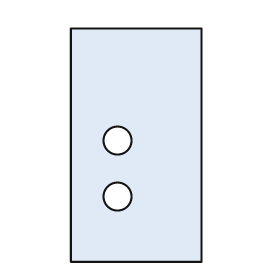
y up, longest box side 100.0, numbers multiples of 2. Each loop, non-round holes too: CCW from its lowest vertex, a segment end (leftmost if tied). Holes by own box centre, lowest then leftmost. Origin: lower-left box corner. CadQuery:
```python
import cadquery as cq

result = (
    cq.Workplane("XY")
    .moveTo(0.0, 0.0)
    .lineTo(56.0, 0.0)
    .lineTo(56.0, 100.0)
    .lineTo(0.0, 100.0)
    .close()
    .moveTo(20.0, 28.0)
    .circle(6.0)
    .moveTo(20.0, 52.0)
    .circle(6.0)
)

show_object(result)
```